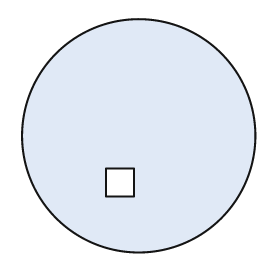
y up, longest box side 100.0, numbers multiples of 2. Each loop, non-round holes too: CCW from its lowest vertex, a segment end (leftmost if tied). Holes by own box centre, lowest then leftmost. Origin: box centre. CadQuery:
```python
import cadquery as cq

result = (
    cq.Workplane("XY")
    .moveTo(0.0, 0.0)
    .circle(50.0)
    .moveTo(-14.0, -26.0)
    .lineTo(-2.0, -26.0)
    .lineTo(-2.0, -14.0)
    .lineTo(-14.0, -14.0)
    .close()
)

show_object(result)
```